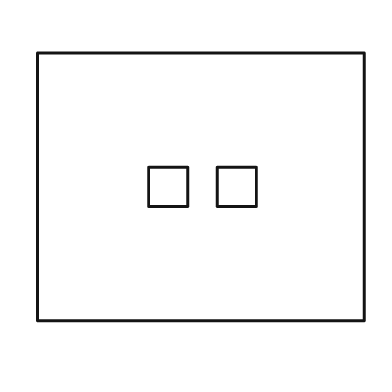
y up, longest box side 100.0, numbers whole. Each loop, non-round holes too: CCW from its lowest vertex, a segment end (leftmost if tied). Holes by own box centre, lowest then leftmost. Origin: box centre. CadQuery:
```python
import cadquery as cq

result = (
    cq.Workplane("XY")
    .moveTo(-50.0, -41.0)
    .lineTo(50.0, -41.0)
    .lineTo(50.0, 41.0)
    .lineTo(-50.0, 41.0)
    .close()
    .moveTo(-16.0, -6.0)
    .lineTo(-4.0, -6.0)
    .lineTo(-4.0, 6.0)
    .lineTo(-16.0, 6.0)
    .close()
    .moveTo(5.0, -6.0)
    .lineTo(17.0, -6.0)
    .lineTo(17.0, 6.0)
    .lineTo(5.0, 6.0)
    .close()
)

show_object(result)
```